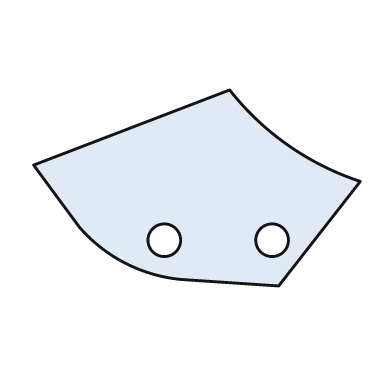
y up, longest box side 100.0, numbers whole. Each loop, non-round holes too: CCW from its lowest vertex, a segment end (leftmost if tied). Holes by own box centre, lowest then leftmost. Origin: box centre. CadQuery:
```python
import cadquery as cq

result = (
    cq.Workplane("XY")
    .moveTo(25.0, -30.0)
    .lineTo(50.0, 2.0)
    .threePointArc((28.0, 13.0), (10.0, 30.0))
    .lineTo(-50.0, 7.0)
    .lineTo(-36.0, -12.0)
    .threePointArc((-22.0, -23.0), (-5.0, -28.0))
    .close()
    .moveTo(-10.0, -16.0)
    .circle(5.0)
    .moveTo(23.0, -16.0)
    .circle(5.0)
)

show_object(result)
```